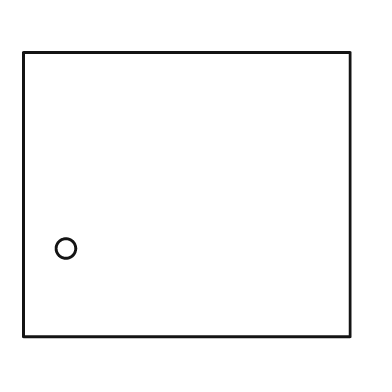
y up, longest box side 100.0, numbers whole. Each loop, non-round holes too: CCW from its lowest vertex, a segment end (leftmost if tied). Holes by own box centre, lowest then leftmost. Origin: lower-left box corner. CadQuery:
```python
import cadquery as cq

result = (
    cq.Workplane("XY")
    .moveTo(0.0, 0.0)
    .lineTo(100.0, 0.0)
    .lineTo(100.0, 87.0)
    .lineTo(0.0, 87.0)
    .close()
    .moveTo(13.0, 27.0)
    .circle(3.0)
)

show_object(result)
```